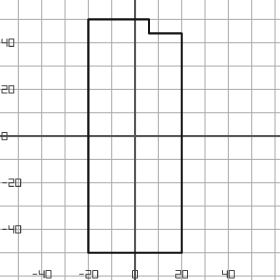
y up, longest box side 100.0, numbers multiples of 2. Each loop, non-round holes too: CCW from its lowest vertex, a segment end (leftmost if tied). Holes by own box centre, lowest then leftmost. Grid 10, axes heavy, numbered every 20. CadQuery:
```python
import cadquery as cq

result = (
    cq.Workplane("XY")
    .moveTo(-20.0, -50.0)
    .lineTo(20.0, -50.0)
    .lineTo(20.0, 44.0)
    .lineTo(6.0, 44.0)
    .lineTo(6.0, 50.0)
    .lineTo(-20.0, 50.0)
    .close()
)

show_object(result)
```